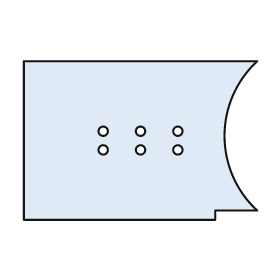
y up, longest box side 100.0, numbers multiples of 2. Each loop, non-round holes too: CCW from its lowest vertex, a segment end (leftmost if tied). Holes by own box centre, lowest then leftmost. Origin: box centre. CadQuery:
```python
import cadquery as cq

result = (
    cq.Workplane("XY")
    .moveTo(-50.0, -34.0)
    .lineTo(32.0, -34.0)
    .lineTo(32.0, -30.0)
    .lineTo(50.0, -30.0)
    .threePointArc((36.0, 2.0), (50.0, 34.0))
    .lineTo(-50.0, 34.0)
    .close()
    .moveTo(-16.0, -4.0)
    .circle(2.0)
    .moveTo(0.0, -4.0)
    .circle(2.0)
    .moveTo(16.0, -4.0)
    .circle(2.0)
    .moveTo(-16.0, 4.0)
    .circle(2.0)
    .moveTo(0.0, 4.0)
    .circle(2.0)
    .moveTo(16.0, 4.0)
    .circle(2.0)
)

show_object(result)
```